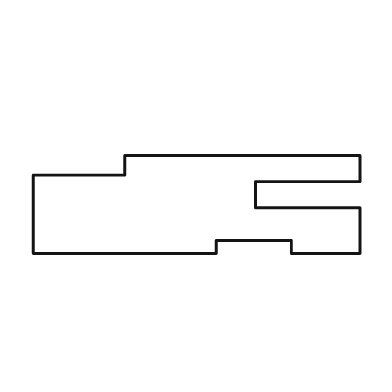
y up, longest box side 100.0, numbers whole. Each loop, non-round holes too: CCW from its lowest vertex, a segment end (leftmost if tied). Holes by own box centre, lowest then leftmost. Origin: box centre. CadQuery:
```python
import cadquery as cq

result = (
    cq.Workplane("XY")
    .moveTo(-50.0, -15.0)
    .lineTo(6.0, -15.0)
    .lineTo(6.0, -11.0)
    .lineTo(29.0, -11.0)
    .lineTo(29.0, -15.0)
    .lineTo(50.0, -15.0)
    .lineTo(50.0, -1.0)
    .lineTo(18.0, -1.0)
    .lineTo(18.0, 7.0)
    .lineTo(50.0, 7.0)
    .lineTo(50.0, 15.0)
    .lineTo(-22.0, 15.0)
    .lineTo(-22.0, 9.0)
    .lineTo(-50.0, 9.0)
    .close()
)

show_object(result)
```